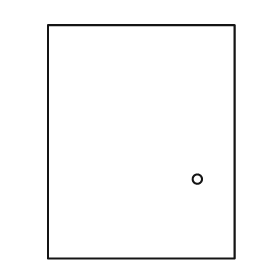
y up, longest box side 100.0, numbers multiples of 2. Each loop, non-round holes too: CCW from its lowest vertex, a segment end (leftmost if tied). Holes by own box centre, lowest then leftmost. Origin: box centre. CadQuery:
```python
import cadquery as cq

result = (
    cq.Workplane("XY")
    .moveTo(-40.0, -50.0)
    .lineTo(40.0, -50.0)
    .lineTo(40.0, 50.0)
    .lineTo(-40.0, 50.0)
    .close()
    .moveTo(24.0, -16.0)
    .circle(2.0)
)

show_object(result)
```